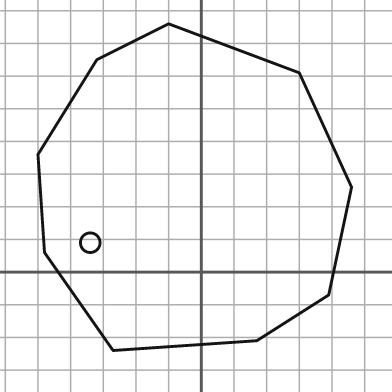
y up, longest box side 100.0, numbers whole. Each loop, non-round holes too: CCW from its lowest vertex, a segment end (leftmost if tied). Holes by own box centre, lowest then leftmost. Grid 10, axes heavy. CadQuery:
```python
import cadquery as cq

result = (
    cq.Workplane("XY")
    .moveTo(-27.0, -24.0)
    .lineTo(17.0, -21.0)
    .lineTo(39.0, -7.0)
    .lineTo(46.0, 26.0)
    .lineTo(30.0, 61.0)
    .lineTo(-10.0, 76.0)
    .lineTo(-32.0, 65.0)
    .lineTo(-50.0, 36.0)
    .lineTo(-48.0, 6.0)
    .close()
    .moveTo(-34.0, 9.0)
    .circle(3.0)
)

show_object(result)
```